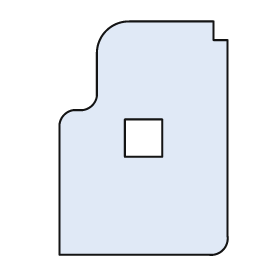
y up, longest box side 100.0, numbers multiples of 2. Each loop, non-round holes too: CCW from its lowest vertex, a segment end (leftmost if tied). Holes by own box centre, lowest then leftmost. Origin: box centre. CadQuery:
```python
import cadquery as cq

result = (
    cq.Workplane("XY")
    .moveTo(-36.0, -50.0)
    .lineTo(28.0, -50.0)
    .threePointArc((34.0, -48.0), (36.0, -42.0))
    .lineTo(36.0, 42.0)
    .lineTo(30.0, 42.0)
    .lineTo(30.0, 50.0)
    .lineTo(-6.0, 50.0)
    .threePointArc((-16.0, 46.0), (-20.0, 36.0))
    .lineTo(-20.0, 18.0)
    .threePointArc((-22.0, 14.0), (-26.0, 12.0))
    .lineTo(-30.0, 12.0)
    .threePointArc((-34.0, 10.0), (-36.0, 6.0))
    .close()
    .moveTo(-8.0, -8.0)
    .lineTo(8.0, -8.0)
    .lineTo(8.0, 8.0)
    .lineTo(-8.0, 8.0)
    .close()
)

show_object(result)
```